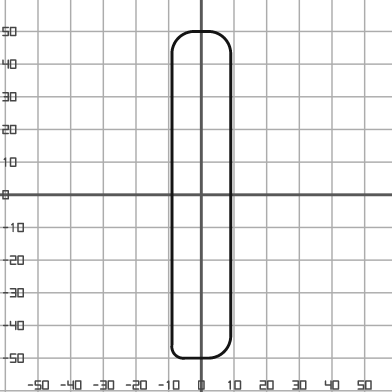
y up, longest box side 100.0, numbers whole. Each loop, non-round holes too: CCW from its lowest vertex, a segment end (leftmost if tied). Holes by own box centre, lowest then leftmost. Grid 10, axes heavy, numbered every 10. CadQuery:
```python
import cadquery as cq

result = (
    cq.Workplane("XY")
    .moveTo(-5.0, -50.0)
    .lineTo(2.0, -50.0)
    .threePointArc((7.0, -48.0), (9.0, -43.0))
    .lineTo(9.0, 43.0)
    .threePointArc((7.0, 48.0), (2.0, 50.0))
    .lineTo(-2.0, 50.0)
    .threePointArc((-7.0, 48.0), (-9.0, 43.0))
    .lineTo(-9.0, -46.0)
    .threePointArc((-8.0, -49.0), (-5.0, -50.0))
    .close()
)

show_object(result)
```